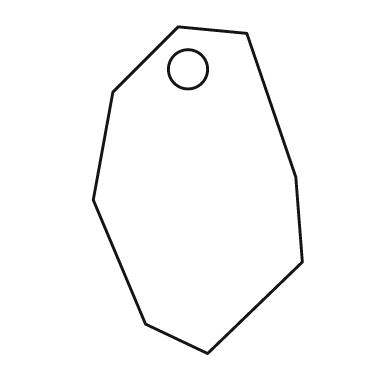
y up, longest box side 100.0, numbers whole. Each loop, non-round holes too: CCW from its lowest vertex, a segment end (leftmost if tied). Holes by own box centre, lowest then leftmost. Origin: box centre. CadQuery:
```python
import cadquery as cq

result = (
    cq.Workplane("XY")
    .moveTo(3.0, -50.0)
    .lineTo(32.0, -22.0)
    .lineTo(30.0, 4.0)
    .lineTo(15.0, 48.0)
    .lineTo(-6.0, 50.0)
    .lineTo(-26.0, 30.0)
    .lineTo(-32.0, -3.0)
    .lineTo(-16.0, -41.0)
    .close()
    .moveTo(-3.0, 37.0)
    .circle(6.0)
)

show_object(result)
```